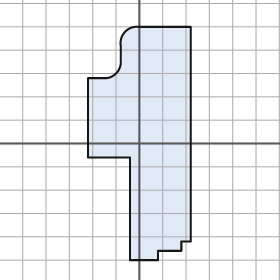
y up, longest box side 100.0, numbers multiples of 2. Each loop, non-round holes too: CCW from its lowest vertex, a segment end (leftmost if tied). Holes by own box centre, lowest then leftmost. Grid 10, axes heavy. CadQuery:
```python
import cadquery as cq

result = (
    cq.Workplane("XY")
    .moveTo(-4.0, -50.0)
    .lineTo(8.0, -50.0)
    .lineTo(8.0, -46.0)
    .lineTo(18.0, -46.0)
    .lineTo(18.0, -42.0)
    .lineTo(22.0, -42.0)
    .lineTo(22.0, 50.0)
    .lineTo(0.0, 50.0)
    .threePointArc((-6.0, 48.0), (-8.0, 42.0))
    .lineTo(-8.0, 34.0)
    .threePointArc((-10.0, 30.0), (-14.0, 28.0))
    .lineTo(-22.0, 28.0)
    .lineTo(-22.0, -6.0)
    .lineTo(-4.0, -6.0)
    .close()
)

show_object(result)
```